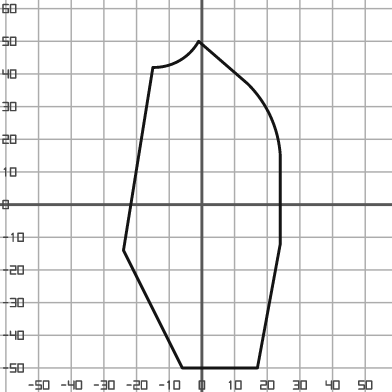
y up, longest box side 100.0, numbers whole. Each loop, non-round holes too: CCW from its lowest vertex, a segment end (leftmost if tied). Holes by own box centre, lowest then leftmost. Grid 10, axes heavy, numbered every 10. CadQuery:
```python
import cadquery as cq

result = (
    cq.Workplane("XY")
    .moveTo(-6.0, -50.0)
    .lineTo(17.0, -50.0)
    .lineTo(24.0, -12.0)
    .lineTo(24.0, 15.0)
    .threePointArc((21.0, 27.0), (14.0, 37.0))
    .lineTo(-1.0, 50.0)
    .threePointArc((-7.0, 44.0), (-15.0, 42.0))
    .lineTo(-24.0, -14.0)
    .close()
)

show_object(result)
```